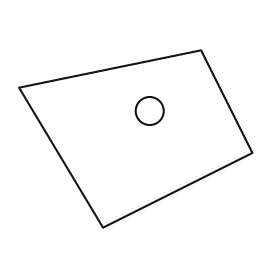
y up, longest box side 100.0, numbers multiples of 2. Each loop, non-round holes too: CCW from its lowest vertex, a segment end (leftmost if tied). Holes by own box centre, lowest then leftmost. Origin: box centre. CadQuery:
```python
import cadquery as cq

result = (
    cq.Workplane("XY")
    .moveTo(-14.0, -38.0)
    .lineTo(50.0, -6.0)
    .lineTo(28.0, 38.0)
    .lineTo(-50.0, 22.0)
    .close()
    .moveTo(6.0, 12.0)
    .circle(6.0)
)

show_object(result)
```